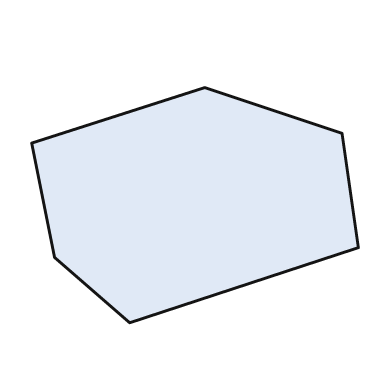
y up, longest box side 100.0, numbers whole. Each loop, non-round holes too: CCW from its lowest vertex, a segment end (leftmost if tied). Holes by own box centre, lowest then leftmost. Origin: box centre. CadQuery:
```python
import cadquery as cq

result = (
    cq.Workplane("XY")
    .moveTo(-20.0, -36.0)
    .lineTo(50.0, -13.0)
    .lineTo(45.0, 22.0)
    .lineTo(3.0, 36.0)
    .lineTo(-50.0, 19.0)
    .lineTo(-43.0, -16.0)
    .close()
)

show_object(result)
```